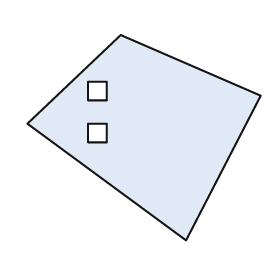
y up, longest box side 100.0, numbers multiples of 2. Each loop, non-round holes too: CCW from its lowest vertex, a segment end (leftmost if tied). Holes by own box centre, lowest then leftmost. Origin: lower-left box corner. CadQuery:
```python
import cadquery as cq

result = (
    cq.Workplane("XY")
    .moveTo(68.0, 0.0)
    .lineTo(100.0, 62.0)
    .lineTo(40.0, 88.0)
    .lineTo(0.0, 50.0)
    .close()
    .moveTo(26.0, 42.0)
    .lineTo(34.0, 42.0)
    .lineTo(34.0, 50.0)
    .lineTo(26.0, 50.0)
    .close()
    .moveTo(26.0, 60.0)
    .lineTo(34.0, 60.0)
    .lineTo(34.0, 68.0)
    .lineTo(26.0, 68.0)
    .close()
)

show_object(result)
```